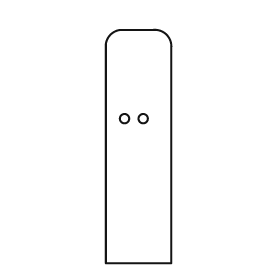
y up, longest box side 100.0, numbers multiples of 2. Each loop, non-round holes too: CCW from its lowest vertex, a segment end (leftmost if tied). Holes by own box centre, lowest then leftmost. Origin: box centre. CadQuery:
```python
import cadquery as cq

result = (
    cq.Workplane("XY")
    .moveTo(-14.0, -50.0)
    .lineTo(14.0, -50.0)
    .lineTo(14.0, 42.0)
    .threePointArc((12.0, 48.0), (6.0, 50.0))
    .lineTo(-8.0, 50.0)
    .threePointArc((-12.0, 48.0), (-14.0, 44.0))
    .close()
    .moveTo(-6.0, 12.0)
    .circle(2.0)
    .moveTo(2.0, 12.0)
    .circle(2.0)
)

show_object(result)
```